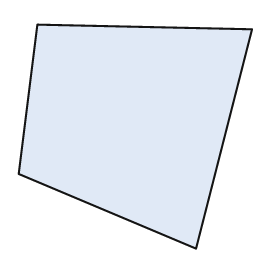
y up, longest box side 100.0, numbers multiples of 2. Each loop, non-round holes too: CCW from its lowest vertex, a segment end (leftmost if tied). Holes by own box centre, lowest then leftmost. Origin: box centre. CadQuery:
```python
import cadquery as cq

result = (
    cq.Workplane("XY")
    .moveTo(26.0, -48.0)
    .lineTo(50.0, 46.0)
    .lineTo(-42.0, 48.0)
    .lineTo(-50.0, -16.0)
    .close()
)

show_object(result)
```